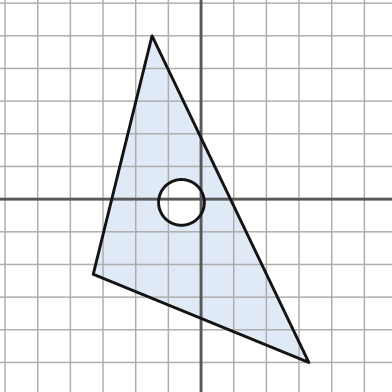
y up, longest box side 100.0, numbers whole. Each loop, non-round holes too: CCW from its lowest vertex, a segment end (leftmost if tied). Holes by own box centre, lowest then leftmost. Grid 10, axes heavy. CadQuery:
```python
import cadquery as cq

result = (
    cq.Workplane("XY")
    .moveTo(33.0, -50.0)
    .lineTo(-15.0, 50.0)
    .lineTo(-33.0, -23.0)
    .close()
    .moveTo(-6.0, -1.0)
    .circle(7.0)
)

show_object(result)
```